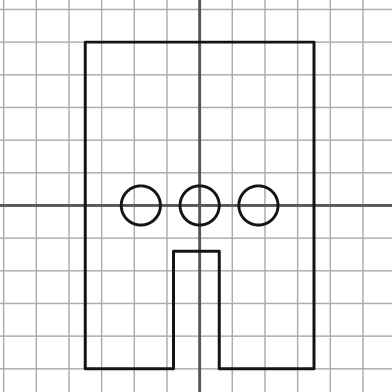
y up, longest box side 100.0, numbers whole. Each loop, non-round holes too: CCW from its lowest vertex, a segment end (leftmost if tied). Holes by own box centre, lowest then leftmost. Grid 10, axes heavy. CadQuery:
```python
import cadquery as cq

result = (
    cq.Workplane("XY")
    .moveTo(-35.0, -50.0)
    .lineTo(-8.0, -50.0)
    .lineTo(-8.0, -14.0)
    .lineTo(6.0, -14.0)
    .lineTo(6.0, -50.0)
    .lineTo(35.0, -50.0)
    .lineTo(35.0, 50.0)
    .lineTo(-35.0, 50.0)
    .close()
    .moveTo(-18.0, 0.0)
    .circle(6.0)
    .moveTo(0.0, 0.0)
    .circle(6.0)
    .moveTo(18.0, 0.0)
    .circle(6.0)
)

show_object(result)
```